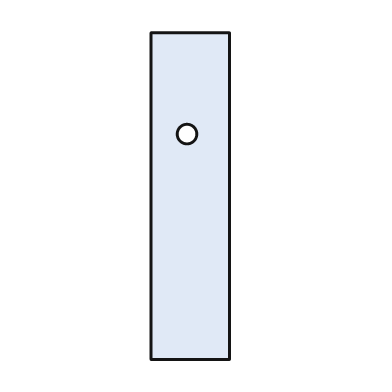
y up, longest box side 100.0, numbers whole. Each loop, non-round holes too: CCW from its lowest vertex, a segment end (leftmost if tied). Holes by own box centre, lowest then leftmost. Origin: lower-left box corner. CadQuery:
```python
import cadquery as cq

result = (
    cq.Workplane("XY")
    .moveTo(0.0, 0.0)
    .lineTo(24.0, 0.0)
    .lineTo(24.0, 100.0)
    .lineTo(0.0, 100.0)
    .close()
    .moveTo(11.0, 69.0)
    .circle(3.0)
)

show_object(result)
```